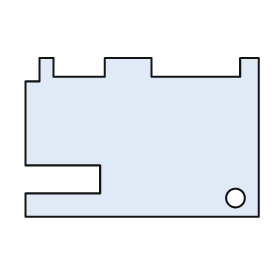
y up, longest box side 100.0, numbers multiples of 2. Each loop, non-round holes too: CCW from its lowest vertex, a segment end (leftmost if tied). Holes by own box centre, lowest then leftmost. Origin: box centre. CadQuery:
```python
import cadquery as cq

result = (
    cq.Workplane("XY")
    .moveTo(-50.0, -34.0)
    .lineTo(50.0, -34.0)
    .lineTo(50.0, 34.0)
    .lineTo(42.0, 34.0)
    .lineTo(42.0, 26.0)
    .lineTo(4.0, 26.0)
    .lineTo(4.0, 34.0)
    .lineTo(-16.0, 34.0)
    .lineTo(-16.0, 26.0)
    .lineTo(-38.0, 26.0)
    .lineTo(-38.0, 34.0)
    .lineTo(-44.0, 34.0)
    .lineTo(-44.0, 24.0)
    .lineTo(-50.0, 24.0)
    .lineTo(-50.0, -12.0)
    .lineTo(-18.0, -12.0)
    .lineTo(-18.0, -24.0)
    .lineTo(-50.0, -24.0)
    .close()
    .moveTo(40.0, -26.0)
    .circle(4.0)
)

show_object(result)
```